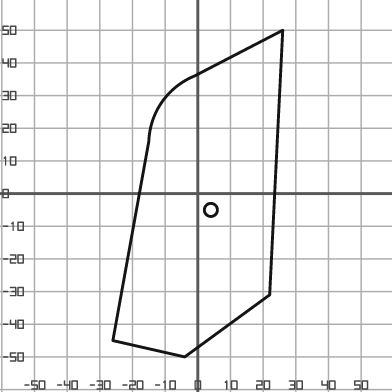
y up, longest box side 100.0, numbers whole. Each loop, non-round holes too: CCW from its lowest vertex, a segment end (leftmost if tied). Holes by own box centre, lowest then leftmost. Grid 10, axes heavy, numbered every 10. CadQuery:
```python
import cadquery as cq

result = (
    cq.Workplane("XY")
    .moveTo(-4.0, -50.0)
    .lineTo(22.0, -31.0)
    .lineTo(26.0, 50.0)
    .lineTo(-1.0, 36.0)
    .threePointArc((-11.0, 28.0), (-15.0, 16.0))
    .lineTo(-26.0, -45.0)
    .close()
    .moveTo(4.0, -5.0)
    .circle(2.0)
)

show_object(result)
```